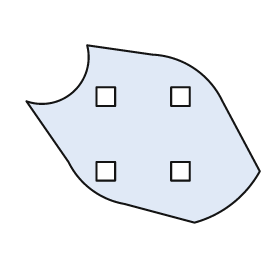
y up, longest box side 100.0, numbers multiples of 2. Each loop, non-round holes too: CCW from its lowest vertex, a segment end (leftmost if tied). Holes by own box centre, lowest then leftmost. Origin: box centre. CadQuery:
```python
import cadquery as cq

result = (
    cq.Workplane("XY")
    .moveTo(22.0, -38.0)
    .threePointArc((38.0, -30.0), (50.0, -16.0))
    .lineTo(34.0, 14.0)
    .threePointArc((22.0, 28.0), (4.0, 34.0))
    .lineTo(-24.0, 38.0)
    .threePointArc((-30.0, 18.0), (-50.0, 14.0))
    .lineTo(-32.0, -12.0)
    .threePointArc((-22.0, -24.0), (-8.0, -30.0))
    .close()
    .moveTo(-20.0, -20.0)
    .lineTo(-12.0, -20.0)
    .lineTo(-12.0, -12.0)
    .lineTo(-20.0, -12.0)
    .close()
    .moveTo(12.0, -20.0)
    .lineTo(20.0, -20.0)
    .lineTo(20.0, -12.0)
    .lineTo(12.0, -12.0)
    .close()
    .moveTo(-20.0, 12.0)
    .lineTo(-12.0, 12.0)
    .lineTo(-12.0, 20.0)
    .lineTo(-20.0, 20.0)
    .close()
    .moveTo(12.0, 12.0)
    .lineTo(20.0, 12.0)
    .lineTo(20.0, 20.0)
    .lineTo(12.0, 20.0)
    .close()
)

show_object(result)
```